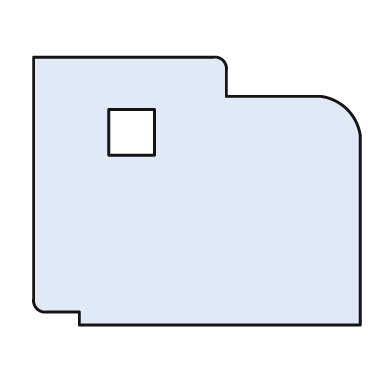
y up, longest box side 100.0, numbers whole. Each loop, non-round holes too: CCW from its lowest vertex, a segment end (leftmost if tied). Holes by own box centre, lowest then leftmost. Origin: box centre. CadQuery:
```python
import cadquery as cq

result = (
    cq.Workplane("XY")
    .moveTo(-36.0, -41.0)
    .lineTo(50.0, -41.0)
    .lineTo(50.0, 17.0)
    .threePointArc((46.0, 25.0), (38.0, 29.0))
    .lineTo(9.0, 29.0)
    .lineTo(9.0, 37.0)
    .threePointArc((8.0, 40.0), (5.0, 41.0))
    .lineTo(-50.0, 41.0)
    .lineTo(-50.0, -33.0)
    .threePointArc((-49.0, -36.0), (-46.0, -37.0))
    .lineTo(-36.0, -37.0)
    .close()
    .moveTo(-27.0, 11.0)
    .lineTo(-13.0, 11.0)
    .lineTo(-13.0, 25.0)
    .lineTo(-27.0, 25.0)
    .close()
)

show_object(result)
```